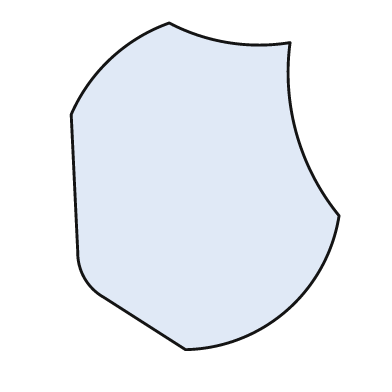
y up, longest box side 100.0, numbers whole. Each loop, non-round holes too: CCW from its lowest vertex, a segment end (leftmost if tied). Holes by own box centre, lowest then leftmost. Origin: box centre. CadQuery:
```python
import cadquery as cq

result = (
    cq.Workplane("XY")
    .moveTo(-6.0, -50.0)
    .threePointArc((25.0, -38.0), (41.0, -9.0))
    .threePointArc((28.0, 16.0), (26.0, 44.0))
    .threePointArc((7.0, 44.0), (-11.0, 50.0))
    .threePointArc((-29.0, 39.0), (-41.0, 22.0))
    .lineTo(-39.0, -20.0)
    .threePointArc((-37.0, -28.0), (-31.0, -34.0))
    .close()
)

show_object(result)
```